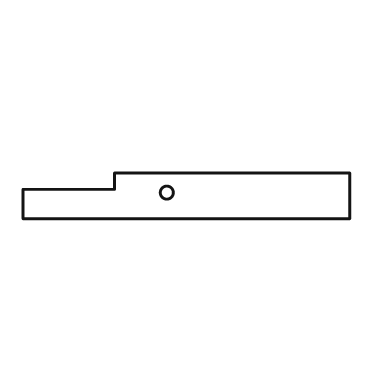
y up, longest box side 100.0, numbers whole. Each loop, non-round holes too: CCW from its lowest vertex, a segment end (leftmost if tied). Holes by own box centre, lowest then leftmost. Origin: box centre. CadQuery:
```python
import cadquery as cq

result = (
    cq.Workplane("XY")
    .moveTo(-50.0, -7.0)
    .lineTo(50.0, -7.0)
    .lineTo(50.0, 7.0)
    .lineTo(-22.0, 7.0)
    .lineTo(-22.0, 2.0)
    .lineTo(-50.0, 2.0)
    .close()
    .moveTo(-6.0, 1.0)
    .circle(2.0)
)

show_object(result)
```